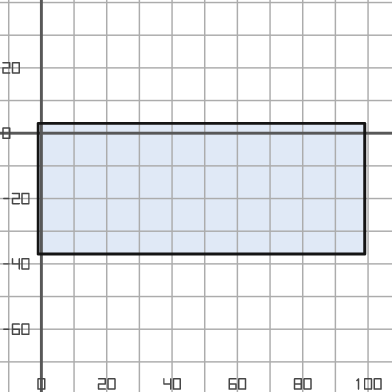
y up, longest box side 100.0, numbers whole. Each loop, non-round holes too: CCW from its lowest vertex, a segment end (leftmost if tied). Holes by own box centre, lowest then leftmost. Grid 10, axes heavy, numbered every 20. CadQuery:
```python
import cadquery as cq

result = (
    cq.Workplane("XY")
    .moveTo(-1.0, -37.0)
    .lineTo(99.0, -37.0)
    .lineTo(99.0, 3.0)
    .lineTo(-1.0, 3.0)
    .close()
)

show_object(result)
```